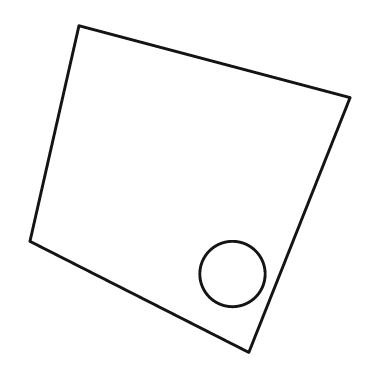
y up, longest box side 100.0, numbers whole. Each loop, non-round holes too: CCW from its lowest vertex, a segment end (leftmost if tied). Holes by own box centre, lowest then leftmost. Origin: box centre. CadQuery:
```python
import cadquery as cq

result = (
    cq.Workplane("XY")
    .moveTo(18.0, -50.0)
    .lineTo(49.0, 28.0)
    .lineTo(-34.0, 50.0)
    .lineTo(-49.0, -16.0)
    .close()
    .moveTo(13.0, -26.0)
    .circle(10.0)
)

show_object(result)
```